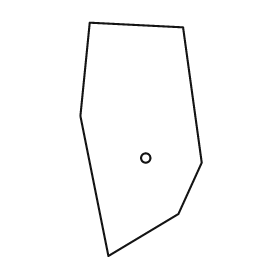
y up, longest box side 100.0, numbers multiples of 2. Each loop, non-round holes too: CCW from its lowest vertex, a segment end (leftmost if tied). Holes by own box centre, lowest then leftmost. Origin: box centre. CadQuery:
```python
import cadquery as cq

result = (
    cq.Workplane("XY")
    .moveTo(-14.0, -50.0)
    .lineTo(16.0, -32.0)
    .lineTo(26.0, -10.0)
    .lineTo(18.0, 48.0)
    .lineTo(-22.0, 50.0)
    .lineTo(-26.0, 10.0)
    .close()
    .moveTo(2.0, -8.0)
    .circle(2.0)
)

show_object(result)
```